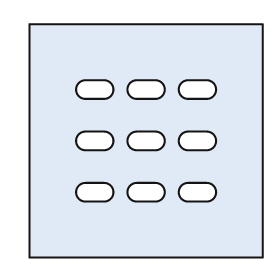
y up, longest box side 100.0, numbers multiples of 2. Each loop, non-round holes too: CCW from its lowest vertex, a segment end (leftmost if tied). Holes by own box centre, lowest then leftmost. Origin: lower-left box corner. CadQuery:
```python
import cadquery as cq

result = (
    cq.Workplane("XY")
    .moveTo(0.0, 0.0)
    .lineTo(100.0, 0.0)
    .lineTo(100.0, 100.0)
    .lineTo(0.0, 100.0)
    .close()
    .moveTo(24.0, 24.0)
    .lineTo(32.0, 24.0)
    .threePointArc((36.0, 28.0), (32.0, 32.0))
    .lineTo(24.0, 32.0)
    .threePointArc((20.0, 28.0), (24.0, 24.0))
    .close()
    .moveTo(46.0, 24.0)
    .lineTo(54.0, 24.0)
    .threePointArc((58.0, 28.0), (54.0, 32.0))
    .lineTo(46.0, 32.0)
    .threePointArc((42.0, 28.0), (46.0, 24.0))
    .close()
    .moveTo(68.0, 24.0)
    .lineTo(76.0, 24.0)
    .threePointArc((80.0, 28.0), (76.0, 32.0))
    .lineTo(68.0, 32.0)
    .threePointArc((64.0, 28.0), (68.0, 24.0))
    .close()
    .moveTo(24.0, 46.0)
    .lineTo(32.0, 46.0)
    .threePointArc((36.0, 50.0), (32.0, 54.0))
    .lineTo(24.0, 54.0)
    .threePointArc((20.0, 50.0), (24.0, 46.0))
    .close()
    .moveTo(46.0, 46.0)
    .lineTo(54.0, 46.0)
    .threePointArc((58.0, 50.0), (54.0, 54.0))
    .lineTo(46.0, 54.0)
    .threePointArc((42.0, 50.0), (46.0, 46.0))
    .close()
    .moveTo(68.0, 46.0)
    .lineTo(76.0, 46.0)
    .threePointArc((80.0, 50.0), (76.0, 54.0))
    .lineTo(68.0, 54.0)
    .threePointArc((64.0, 50.0), (68.0, 46.0))
    .close()
    .moveTo(24.0, 68.0)
    .lineTo(32.0, 68.0)
    .threePointArc((36.0, 72.0), (32.0, 76.0))
    .lineTo(24.0, 76.0)
    .threePointArc((20.0, 72.0), (24.0, 68.0))
    .close()
    .moveTo(46.0, 68.0)
    .lineTo(54.0, 68.0)
    .threePointArc((58.0, 72.0), (54.0, 76.0))
    .lineTo(46.0, 76.0)
    .threePointArc((42.0, 72.0), (46.0, 68.0))
    .close()
    .moveTo(68.0, 68.0)
    .lineTo(76.0, 68.0)
    .threePointArc((80.0, 72.0), (76.0, 76.0))
    .lineTo(68.0, 76.0)
    .threePointArc((64.0, 72.0), (68.0, 68.0))
    .close()
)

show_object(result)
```